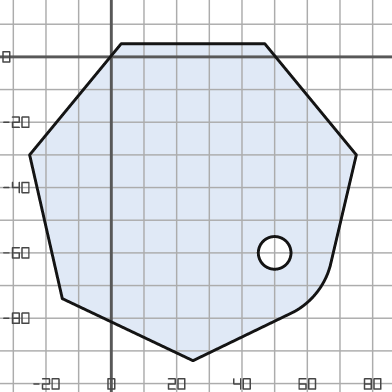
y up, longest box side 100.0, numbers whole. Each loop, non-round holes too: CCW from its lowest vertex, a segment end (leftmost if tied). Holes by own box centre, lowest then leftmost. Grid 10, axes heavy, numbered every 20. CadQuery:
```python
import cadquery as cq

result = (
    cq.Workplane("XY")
    .moveTo(25.0, -93.0)
    .lineTo(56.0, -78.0)
    .threePointArc((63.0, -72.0), (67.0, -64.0))
    .lineTo(75.0, -30.0)
    .lineTo(47.0, 4.0)
    .lineTo(3.0, 4.0)
    .lineTo(-25.0, -30.0)
    .lineTo(-15.0, -74.0)
    .close()
    .moveTo(50.0, -60.0)
    .circle(5.0)
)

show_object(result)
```